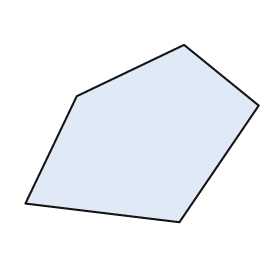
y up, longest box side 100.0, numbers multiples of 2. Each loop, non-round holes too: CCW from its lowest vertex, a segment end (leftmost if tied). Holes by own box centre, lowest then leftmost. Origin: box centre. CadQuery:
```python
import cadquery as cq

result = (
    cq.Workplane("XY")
    .moveTo(16.0, -38.0)
    .lineTo(50.0, 12.0)
    .lineTo(18.0, 38.0)
    .lineTo(-28.0, 16.0)
    .lineTo(-50.0, -30.0)
    .close()
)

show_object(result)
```